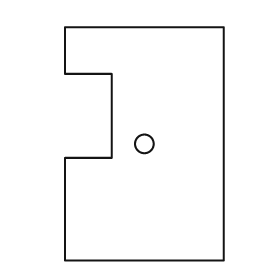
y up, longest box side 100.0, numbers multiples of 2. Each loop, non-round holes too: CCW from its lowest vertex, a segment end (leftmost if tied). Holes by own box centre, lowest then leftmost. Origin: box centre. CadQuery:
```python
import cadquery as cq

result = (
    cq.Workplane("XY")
    .moveTo(-34.0, -50.0)
    .lineTo(34.0, -50.0)
    .lineTo(34.0, 50.0)
    .lineTo(-34.0, 50.0)
    .lineTo(-34.0, 30.0)
    .lineTo(-14.0, 30.0)
    .lineTo(-14.0, -6.0)
    .lineTo(-34.0, -6.0)
    .close()
    .moveTo(0.0, 0.0)
    .circle(4.0)
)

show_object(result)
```